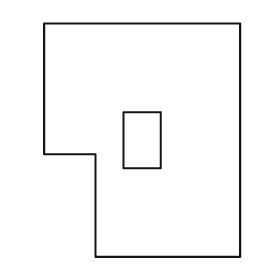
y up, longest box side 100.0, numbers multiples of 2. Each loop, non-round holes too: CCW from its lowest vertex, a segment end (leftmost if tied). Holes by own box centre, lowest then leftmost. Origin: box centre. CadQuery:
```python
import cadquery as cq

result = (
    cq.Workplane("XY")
    .moveTo(-20.0, -50.0)
    .lineTo(42.0, -50.0)
    .lineTo(42.0, 50.0)
    .lineTo(-42.0, 50.0)
    .lineTo(-42.0, -6.0)
    .lineTo(-20.0, -6.0)
    .close()
    .moveTo(-8.0, -12.0)
    .lineTo(8.0, -12.0)
    .lineTo(8.0, 12.0)
    .lineTo(-8.0, 12.0)
    .close()
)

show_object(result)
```